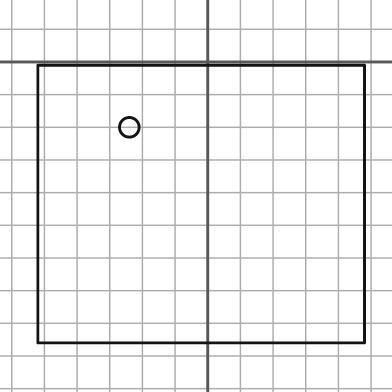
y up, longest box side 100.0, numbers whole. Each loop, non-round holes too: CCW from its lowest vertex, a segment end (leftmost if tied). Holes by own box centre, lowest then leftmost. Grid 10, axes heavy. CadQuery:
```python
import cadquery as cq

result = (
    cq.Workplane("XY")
    .moveTo(-52.0, -86.0)
    .lineTo(48.0, -86.0)
    .lineTo(48.0, -1.0)
    .lineTo(-52.0, -1.0)
    .close()
    .moveTo(-24.0, -20.0)
    .circle(3.0)
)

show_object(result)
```